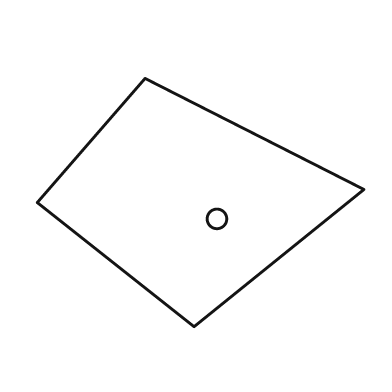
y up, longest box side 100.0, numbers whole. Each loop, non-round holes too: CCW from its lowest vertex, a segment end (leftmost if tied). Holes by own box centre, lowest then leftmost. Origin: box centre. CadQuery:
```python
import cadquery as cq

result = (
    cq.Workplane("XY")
    .moveTo(-2.0, -38.0)
    .lineTo(50.0, 4.0)
    .lineTo(-17.0, 38.0)
    .lineTo(-50.0, 0.0)
    .close()
    .moveTo(5.0, -5.0)
    .circle(3.0)
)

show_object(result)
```